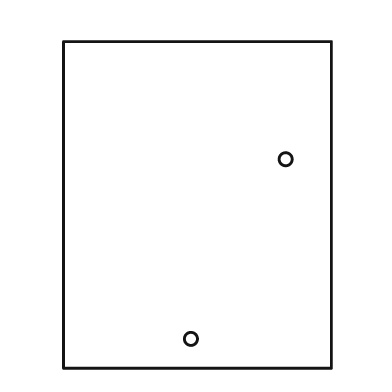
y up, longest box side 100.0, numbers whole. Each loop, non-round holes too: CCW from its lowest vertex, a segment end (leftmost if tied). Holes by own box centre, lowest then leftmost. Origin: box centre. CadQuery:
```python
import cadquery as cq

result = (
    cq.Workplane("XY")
    .moveTo(-41.0, -50.0)
    .lineTo(41.0, -50.0)
    .lineTo(41.0, 50.0)
    .lineTo(-41.0, 50.0)
    .close()
    .moveTo(-2.0, -41.0)
    .circle(2.0)
    .moveTo(27.0, 14.0)
    .circle(2.0)
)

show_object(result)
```